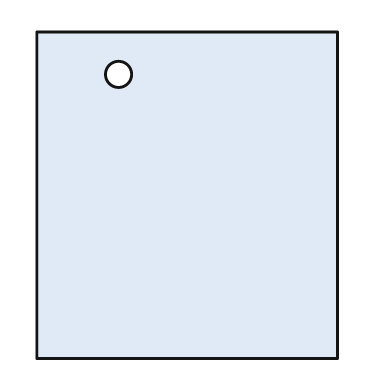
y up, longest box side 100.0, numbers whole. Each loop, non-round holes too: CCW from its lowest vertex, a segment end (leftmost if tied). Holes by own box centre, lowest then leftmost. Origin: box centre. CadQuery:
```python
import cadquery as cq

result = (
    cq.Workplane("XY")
    .moveTo(-46.0, -50.0)
    .lineTo(46.0, -50.0)
    .lineTo(46.0, 50.0)
    .lineTo(-46.0, 50.0)
    .close()
    .moveTo(-21.0, 37.0)
    .circle(4.0)
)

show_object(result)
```